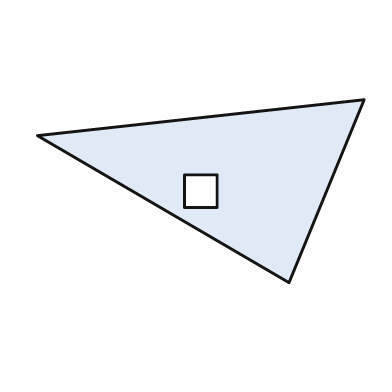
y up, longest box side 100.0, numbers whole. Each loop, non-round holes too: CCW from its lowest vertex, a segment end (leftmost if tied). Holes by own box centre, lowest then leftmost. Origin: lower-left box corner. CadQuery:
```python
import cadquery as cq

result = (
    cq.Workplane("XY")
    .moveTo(77.0, 0.0)
    .lineTo(100.0, 56.0)
    .lineTo(0.0, 45.0)
    .close()
    .moveTo(45.0, 23.0)
    .lineTo(55.0, 23.0)
    .lineTo(55.0, 33.0)
    .lineTo(45.0, 33.0)
    .close()
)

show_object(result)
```